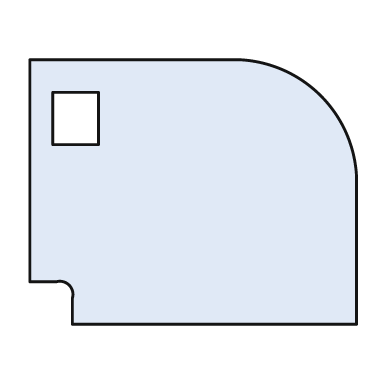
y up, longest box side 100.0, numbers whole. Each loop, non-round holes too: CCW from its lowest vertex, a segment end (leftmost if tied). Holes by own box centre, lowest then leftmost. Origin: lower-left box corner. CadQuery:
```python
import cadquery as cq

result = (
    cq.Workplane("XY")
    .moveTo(13.0, 0.0)
    .lineTo(100.0, 0.0)
    .lineTo(100.0, 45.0)
    .threePointArc((89.0, 70.0), (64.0, 81.0))
    .lineTo(0.0, 81.0)
    .lineTo(0.0, 13.0)
    .lineTo(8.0, 13.0)
    .threePointArc((12.0, 12.0), (13.0, 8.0))
    .close()
    .moveTo(7.0, 55.0)
    .lineTo(21.0, 55.0)
    .lineTo(21.0, 71.0)
    .lineTo(7.0, 71.0)
    .close()
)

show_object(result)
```